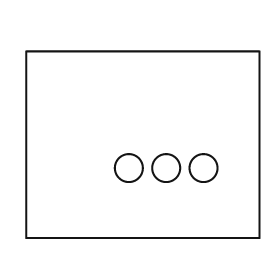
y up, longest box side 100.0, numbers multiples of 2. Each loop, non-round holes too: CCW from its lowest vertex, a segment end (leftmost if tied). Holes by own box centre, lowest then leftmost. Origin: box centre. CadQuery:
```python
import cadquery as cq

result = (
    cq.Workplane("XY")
    .moveTo(-50.0, -40.0)
    .lineTo(50.0, -40.0)
    .lineTo(50.0, 40.0)
    .lineTo(-50.0, 40.0)
    .close()
    .moveTo(-6.0, -10.0)
    .circle(6.0)
    .moveTo(10.0, -10.0)
    .circle(6.0)
    .moveTo(26.0, -10.0)
    .circle(6.0)
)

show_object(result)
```